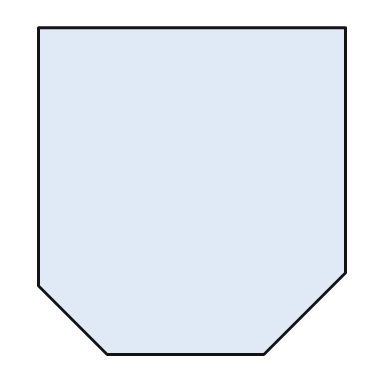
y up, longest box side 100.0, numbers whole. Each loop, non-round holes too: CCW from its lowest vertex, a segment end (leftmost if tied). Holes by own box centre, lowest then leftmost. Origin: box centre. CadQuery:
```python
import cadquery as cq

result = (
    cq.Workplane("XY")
    .moveTo(-26.0, -50.0)
    .lineTo(22.0, -50.0)
    .lineTo(47.0, -25.0)
    .lineTo(47.0, 50.0)
    .lineTo(-47.0, 50.0)
    .lineTo(-47.0, -29.0)
    .close()
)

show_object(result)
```